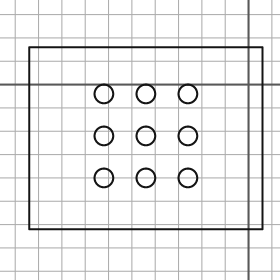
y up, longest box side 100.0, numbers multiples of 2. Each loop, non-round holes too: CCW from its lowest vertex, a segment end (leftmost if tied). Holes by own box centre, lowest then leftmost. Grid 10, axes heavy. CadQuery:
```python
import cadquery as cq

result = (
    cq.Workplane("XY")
    .moveTo(-94.0, -62.0)
    .lineTo(6.0, -62.0)
    .lineTo(6.0, 16.0)
    .lineTo(-94.0, 16.0)
    .close()
    .moveTo(-62.0, -40.0)
    .circle(4.0)
    .moveTo(-44.0, -40.0)
    .circle(4.0)
    .moveTo(-26.0, -40.0)
    .circle(4.0)
    .moveTo(-62.0, -22.0)
    .circle(4.0)
    .moveTo(-44.0, -22.0)
    .circle(4.0)
    .moveTo(-26.0, -22.0)
    .circle(4.0)
    .moveTo(-62.0, -4.0)
    .circle(4.0)
    .moveTo(-44.0, -4.0)
    .circle(4.0)
    .moveTo(-26.0, -4.0)
    .circle(4.0)
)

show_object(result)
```